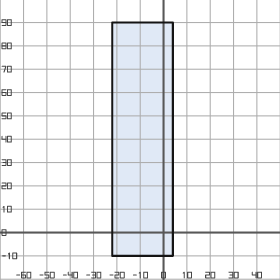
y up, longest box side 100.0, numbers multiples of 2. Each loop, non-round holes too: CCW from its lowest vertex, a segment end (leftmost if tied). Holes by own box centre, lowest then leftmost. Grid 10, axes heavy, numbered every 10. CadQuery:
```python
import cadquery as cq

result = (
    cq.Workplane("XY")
    .moveTo(-22.0, -10.0)
    .lineTo(4.0, -10.0)
    .lineTo(4.0, 90.0)
    .lineTo(-22.0, 90.0)
    .close()
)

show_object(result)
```